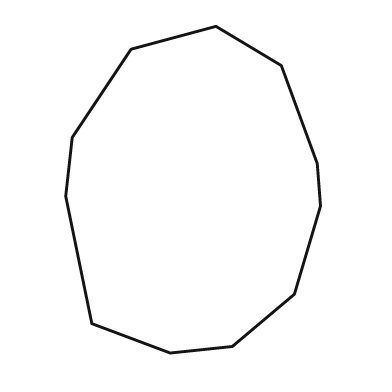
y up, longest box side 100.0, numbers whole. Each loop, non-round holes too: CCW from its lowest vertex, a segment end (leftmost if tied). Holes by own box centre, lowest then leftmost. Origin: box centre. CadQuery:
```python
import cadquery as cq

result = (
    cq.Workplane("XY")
    .moveTo(-7.0, -50.0)
    .lineTo(12.0, -48.0)
    .lineTo(31.0, -32.0)
    .lineTo(39.0, -5.0)
    .lineTo(38.0, 8.0)
    .lineTo(27.0, 38.0)
    .lineTo(7.0, 50.0)
    .lineTo(-19.0, 43.0)
    .lineTo(-37.0, 16.0)
    .lineTo(-39.0, -2.0)
    .lineTo(-31.0, -41.0)
    .close()
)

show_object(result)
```